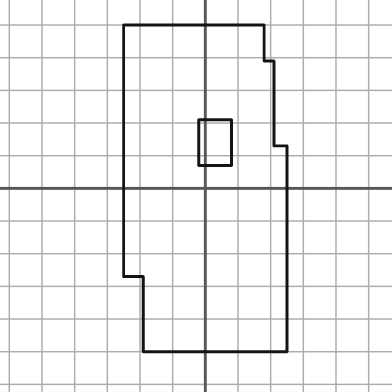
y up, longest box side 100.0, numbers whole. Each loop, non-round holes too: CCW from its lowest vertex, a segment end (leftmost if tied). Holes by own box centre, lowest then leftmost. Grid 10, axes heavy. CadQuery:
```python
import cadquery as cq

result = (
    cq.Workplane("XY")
    .moveTo(-19.0, -50.0)
    .lineTo(25.0, -50.0)
    .lineTo(25.0, 13.0)
    .lineTo(21.0, 13.0)
    .lineTo(21.0, 39.0)
    .lineTo(18.0, 39.0)
    .lineTo(18.0, 50.0)
    .lineTo(-25.0, 50.0)
    .lineTo(-25.0, -27.0)
    .lineTo(-19.0, -27.0)
    .close()
    .moveTo(-2.0, 7.0)
    .lineTo(8.0, 7.0)
    .lineTo(8.0, 21.0)
    .lineTo(-2.0, 21.0)
    .close()
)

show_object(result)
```